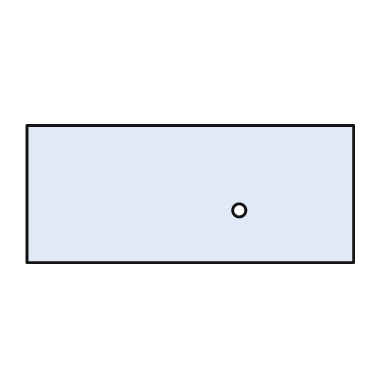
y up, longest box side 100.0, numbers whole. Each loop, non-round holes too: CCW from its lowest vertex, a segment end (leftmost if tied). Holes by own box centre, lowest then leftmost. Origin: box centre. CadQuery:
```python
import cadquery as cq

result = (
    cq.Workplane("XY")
    .moveTo(-50.0, -21.0)
    .lineTo(50.0, -21.0)
    .lineTo(50.0, 21.0)
    .lineTo(-50.0, 21.0)
    .close()
    .moveTo(15.0, -5.0)
    .circle(2.0)
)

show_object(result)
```